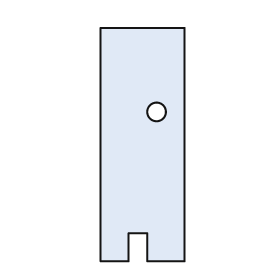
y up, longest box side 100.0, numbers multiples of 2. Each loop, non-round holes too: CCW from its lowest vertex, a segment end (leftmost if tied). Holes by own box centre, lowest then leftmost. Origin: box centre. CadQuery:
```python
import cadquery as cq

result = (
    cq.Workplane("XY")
    .moveTo(-18.0, -50.0)
    .lineTo(-6.0, -50.0)
    .lineTo(-6.0, -38.0)
    .lineTo(2.0, -38.0)
    .lineTo(2.0, -50.0)
    .lineTo(18.0, -50.0)
    .lineTo(18.0, 50.0)
    .lineTo(-18.0, 50.0)
    .close()
    .moveTo(6.0, 14.0)
    .circle(4.0)
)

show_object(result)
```